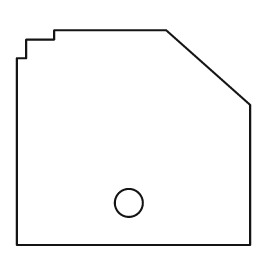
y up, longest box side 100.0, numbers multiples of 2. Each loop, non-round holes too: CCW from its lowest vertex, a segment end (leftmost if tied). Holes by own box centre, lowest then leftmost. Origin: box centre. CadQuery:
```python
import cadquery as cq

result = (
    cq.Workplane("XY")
    .moveTo(-50.0, -46.0)
    .lineTo(50.0, -46.0)
    .lineTo(50.0, 14.0)
    .lineTo(14.0, 46.0)
    .lineTo(-34.0, 46.0)
    .lineTo(-34.0, 42.0)
    .lineTo(-46.0, 42.0)
    .lineTo(-46.0, 34.0)
    .lineTo(-50.0, 34.0)
    .close()
    .moveTo(-2.0, -28.0)
    .circle(6.0)
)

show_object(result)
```